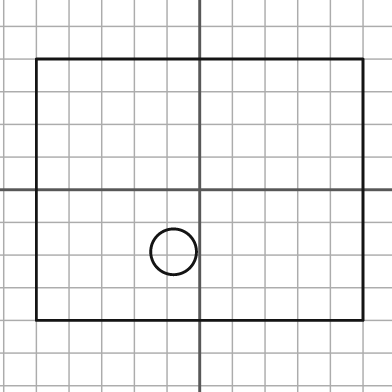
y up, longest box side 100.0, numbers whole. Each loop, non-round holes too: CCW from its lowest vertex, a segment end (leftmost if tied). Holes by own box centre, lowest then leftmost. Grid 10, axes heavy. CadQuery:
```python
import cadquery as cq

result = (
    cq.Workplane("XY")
    .moveTo(-50.0, -40.0)
    .lineTo(50.0, -40.0)
    .lineTo(50.0, 40.0)
    .lineTo(-50.0, 40.0)
    .close()
    .moveTo(-8.0, -19.0)
    .circle(7.0)
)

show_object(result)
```